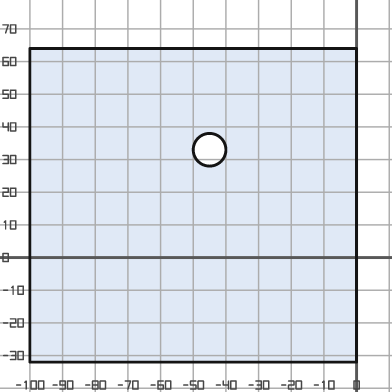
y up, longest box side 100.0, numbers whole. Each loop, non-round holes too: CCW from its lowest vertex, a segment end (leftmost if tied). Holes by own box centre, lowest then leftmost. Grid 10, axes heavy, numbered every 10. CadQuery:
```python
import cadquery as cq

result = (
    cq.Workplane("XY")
    .moveTo(-100.0, -32.0)
    .lineTo(0.0, -32.0)
    .lineTo(0.0, 64.0)
    .lineTo(-100.0, 64.0)
    .close()
    .moveTo(-45.0, 33.0)
    .circle(5.0)
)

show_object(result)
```